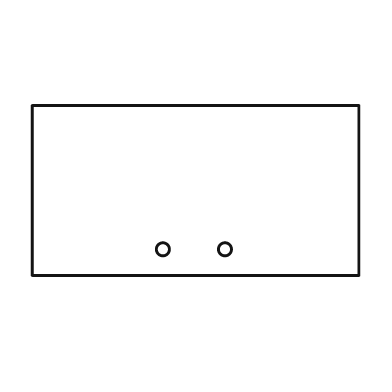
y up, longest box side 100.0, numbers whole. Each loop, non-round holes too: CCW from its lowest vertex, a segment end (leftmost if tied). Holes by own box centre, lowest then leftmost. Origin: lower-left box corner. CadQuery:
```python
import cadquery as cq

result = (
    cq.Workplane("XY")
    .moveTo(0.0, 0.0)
    .lineTo(100.0, 0.0)
    .lineTo(100.0, 52.0)
    .lineTo(0.0, 52.0)
    .close()
    .moveTo(40.0, 8.0)
    .circle(2.0)
    .moveTo(59.0, 8.0)
    .circle(2.0)
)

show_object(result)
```